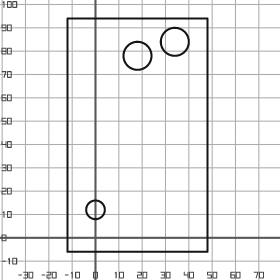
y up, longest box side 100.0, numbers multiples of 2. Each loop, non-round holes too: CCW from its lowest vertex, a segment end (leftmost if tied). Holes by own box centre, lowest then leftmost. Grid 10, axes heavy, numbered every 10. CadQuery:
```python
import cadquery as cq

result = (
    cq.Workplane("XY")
    .moveTo(-12.0, -6.0)
    .lineTo(48.0, -6.0)
    .lineTo(48.0, 94.0)
    .lineTo(-12.0, 94.0)
    .close()
    .moveTo(0.0, 12.0)
    .circle(4.0)
    .moveTo(18.0, 78.0)
    .circle(6.0)
    .moveTo(34.0, 84.0)
    .circle(6.0)
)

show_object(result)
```